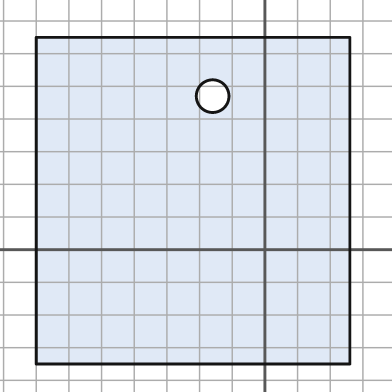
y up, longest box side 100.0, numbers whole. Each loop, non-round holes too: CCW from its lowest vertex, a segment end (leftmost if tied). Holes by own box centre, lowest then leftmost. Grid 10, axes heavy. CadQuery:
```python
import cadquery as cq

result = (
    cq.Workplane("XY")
    .moveTo(-70.0, -35.0)
    .lineTo(26.0, -35.0)
    .lineTo(26.0, 65.0)
    .lineTo(-70.0, 65.0)
    .close()
    .moveTo(-16.0, 47.0)
    .circle(5.0)
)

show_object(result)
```